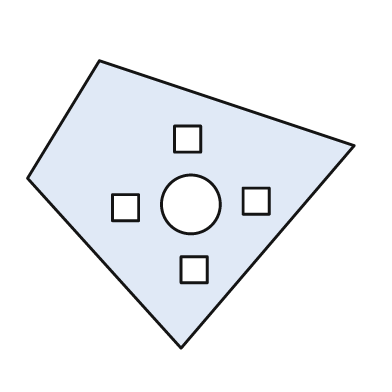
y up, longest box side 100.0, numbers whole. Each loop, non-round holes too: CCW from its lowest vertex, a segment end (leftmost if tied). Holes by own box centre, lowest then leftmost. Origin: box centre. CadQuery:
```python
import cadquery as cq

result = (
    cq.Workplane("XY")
    .moveTo(-3.0, -44.0)
    .lineTo(50.0, 18.0)
    .lineTo(-28.0, 44.0)
    .lineTo(-50.0, 8.0)
    .close()
    .moveTo(-3.0, -24.0)
    .lineTo(5.0, -24.0)
    .lineTo(5.0, -16.0)
    .lineTo(-3.0, -16.0)
    .close()
    .moveTo(-24.0, -5.0)
    .lineTo(-16.0, -5.0)
    .lineTo(-16.0, 3.0)
    .lineTo(-24.0, 3.0)
    .close()
    .moveTo(0.0, 0.0)
    .circle(9.0)
    .moveTo(16.0, -3.0)
    .lineTo(24.0, -3.0)
    .lineTo(24.0, 5.0)
    .lineTo(16.0, 5.0)
    .close()
    .moveTo(-5.0, 16.0)
    .lineTo(3.0, 16.0)
    .lineTo(3.0, 24.0)
    .lineTo(-5.0, 24.0)
    .close()
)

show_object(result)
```